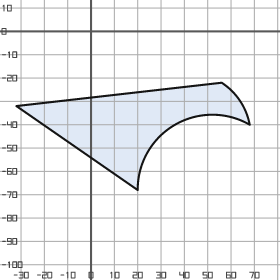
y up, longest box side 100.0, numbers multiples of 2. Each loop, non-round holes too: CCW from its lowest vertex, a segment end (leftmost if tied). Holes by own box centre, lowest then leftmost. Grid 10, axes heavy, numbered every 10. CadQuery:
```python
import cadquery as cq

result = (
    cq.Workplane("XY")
    .moveTo(20.0, -68.0)
    .threePointArc((36.0, -40.0), (68.0, -40.0))
    .threePointArc((64.0, -30.0), (56.0, -22.0))
    .lineTo(-32.0, -32.0)
    .close()
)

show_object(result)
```